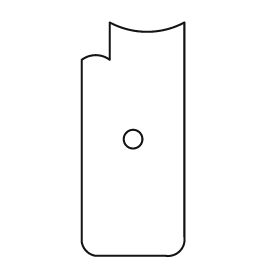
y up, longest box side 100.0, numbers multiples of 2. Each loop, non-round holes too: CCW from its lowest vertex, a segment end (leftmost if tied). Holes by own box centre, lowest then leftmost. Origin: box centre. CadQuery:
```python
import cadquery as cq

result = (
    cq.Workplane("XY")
    .moveTo(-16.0, -50.0)
    .lineTo(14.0, -50.0)
    .threePointArc((20.0, -48.0), (22.0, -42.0))
    .lineTo(22.0, 50.0)
    .threePointArc((6.0, 46.0), (-10.0, 50.0))
    .lineTo(-10.0, 34.0)
    .threePointArc((-16.0, 36.0), (-22.0, 34.0))
    .lineTo(-22.0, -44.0)
    .threePointArc((-20.0, -48.0), (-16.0, -50.0))
    .close()
    .moveTo(0.0, 0.0)
    .circle(4.0)
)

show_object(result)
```